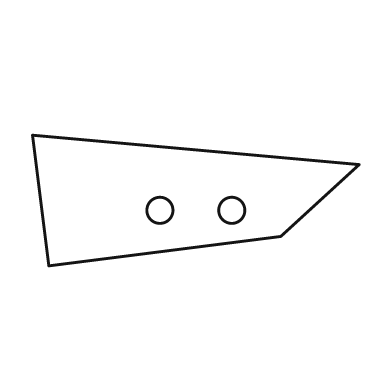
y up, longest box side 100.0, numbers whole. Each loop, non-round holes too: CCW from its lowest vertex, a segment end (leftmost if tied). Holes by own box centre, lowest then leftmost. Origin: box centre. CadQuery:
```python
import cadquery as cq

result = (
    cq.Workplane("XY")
    .moveTo(-45.0, -20.0)
    .lineTo(26.0, -11.0)
    .lineTo(50.0, 11.0)
    .lineTo(-50.0, 20.0)
    .close()
    .moveTo(-11.0, -3.0)
    .circle(4.0)
    .moveTo(11.0, -3.0)
    .circle(4.0)
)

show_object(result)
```